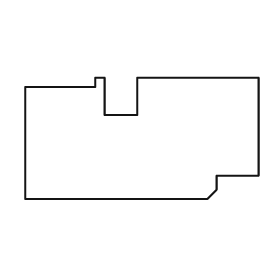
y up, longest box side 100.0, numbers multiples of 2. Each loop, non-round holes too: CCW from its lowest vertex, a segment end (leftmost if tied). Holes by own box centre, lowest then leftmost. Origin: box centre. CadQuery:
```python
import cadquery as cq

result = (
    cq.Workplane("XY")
    .moveTo(-50.0, -26.0)
    .lineTo(28.0, -26.0)
    .lineTo(32.0, -22.0)
    .lineTo(32.0, -16.0)
    .lineTo(50.0, -16.0)
    .lineTo(50.0, 26.0)
    .lineTo(-2.0, 26.0)
    .lineTo(-2.0, 10.0)
    .lineTo(-16.0, 10.0)
    .lineTo(-16.0, 26.0)
    .lineTo(-20.0, 26.0)
    .lineTo(-20.0, 22.0)
    .lineTo(-50.0, 22.0)
    .close()
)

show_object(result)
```